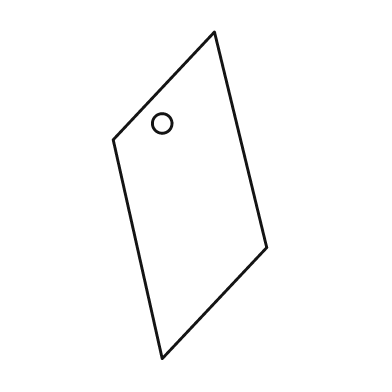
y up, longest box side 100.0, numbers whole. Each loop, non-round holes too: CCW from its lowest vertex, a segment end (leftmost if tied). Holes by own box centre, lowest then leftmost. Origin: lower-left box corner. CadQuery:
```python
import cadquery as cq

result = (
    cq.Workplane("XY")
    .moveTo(15.0, 0.0)
    .lineTo(47.0, 34.0)
    .lineTo(31.0, 100.0)
    .lineTo(0.0, 67.0)
    .close()
    .moveTo(15.0, 72.0)
    .circle(3.0)
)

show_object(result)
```